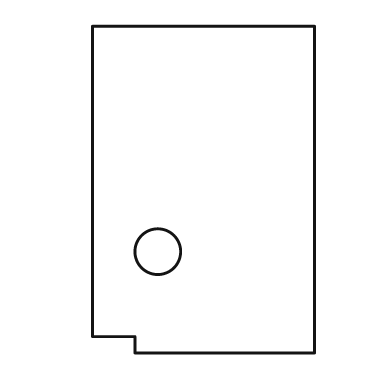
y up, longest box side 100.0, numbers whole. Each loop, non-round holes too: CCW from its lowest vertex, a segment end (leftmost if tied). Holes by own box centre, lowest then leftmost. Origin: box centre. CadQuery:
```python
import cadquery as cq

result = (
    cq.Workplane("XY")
    .moveTo(-21.0, -50.0)
    .lineTo(34.0, -50.0)
    .lineTo(34.0, 50.0)
    .lineTo(-34.0, 50.0)
    .lineTo(-34.0, -45.0)
    .lineTo(-21.0, -45.0)
    .close()
    .moveTo(-14.0, -19.0)
    .circle(7.0)
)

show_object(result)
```